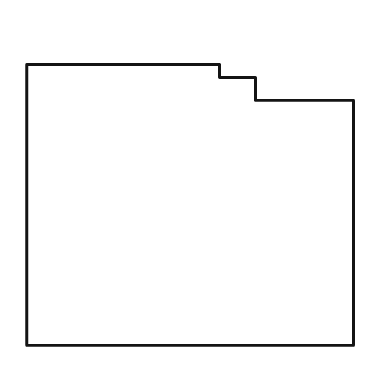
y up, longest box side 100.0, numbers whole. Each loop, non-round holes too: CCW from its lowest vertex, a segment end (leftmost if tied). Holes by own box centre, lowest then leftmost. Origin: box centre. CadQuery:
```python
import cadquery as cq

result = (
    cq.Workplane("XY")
    .moveTo(-50.0, -43.0)
    .lineTo(50.0, -43.0)
    .lineTo(50.0, 32.0)
    .lineTo(20.0, 32.0)
    .lineTo(20.0, 39.0)
    .lineTo(9.0, 39.0)
    .lineTo(9.0, 43.0)
    .lineTo(-50.0, 43.0)
    .close()
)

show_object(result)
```